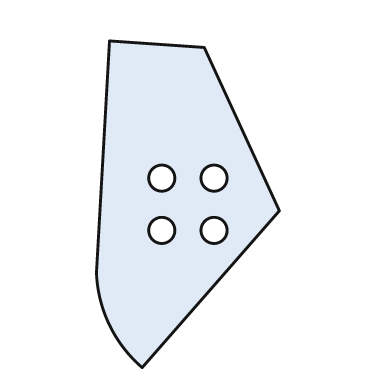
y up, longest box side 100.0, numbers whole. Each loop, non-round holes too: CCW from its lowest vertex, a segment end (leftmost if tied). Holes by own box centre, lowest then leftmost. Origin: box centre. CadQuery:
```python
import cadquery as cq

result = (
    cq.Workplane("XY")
    .moveTo(-14.0, -50.0)
    .lineTo(28.0, -2.0)
    .lineTo(5.0, 48.0)
    .lineTo(-24.0, 50.0)
    .lineTo(-28.0, -21.0)
    .threePointArc((-24.0, -37.0), (-14.0, -50.0))
    .close()
    .moveTo(-8.0, -8.0)
    .circle(4.0)
    .moveTo(8.0, -8.0)
    .circle(4.0)
    .moveTo(-8.0, 8.0)
    .circle(4.0)
    .moveTo(8.0, 8.0)
    .circle(4.0)
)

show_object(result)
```